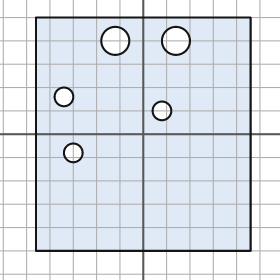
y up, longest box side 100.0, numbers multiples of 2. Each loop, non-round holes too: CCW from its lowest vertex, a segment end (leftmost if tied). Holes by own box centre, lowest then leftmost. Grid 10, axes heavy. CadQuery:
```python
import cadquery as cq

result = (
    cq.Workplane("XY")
    .moveTo(-46.0, -50.0)
    .lineTo(46.0, -50.0)
    .lineTo(46.0, 50.0)
    .lineTo(-46.0, 50.0)
    .close()
    .moveTo(-30.0, -8.0)
    .circle(4.0)
    .moveTo(8.0, 10.0)
    .circle(4.0)
    .moveTo(-34.0, 16.0)
    .circle(4.0)
    .moveTo(-12.0, 40.0)
    .circle(6.0)
    .moveTo(14.0, 40.0)
    .circle(6.0)
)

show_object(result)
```